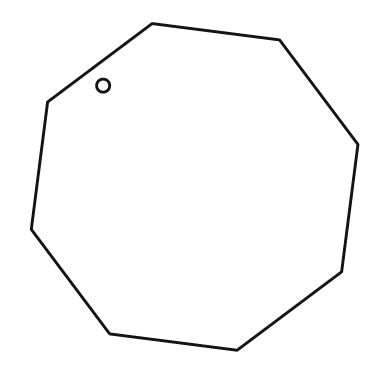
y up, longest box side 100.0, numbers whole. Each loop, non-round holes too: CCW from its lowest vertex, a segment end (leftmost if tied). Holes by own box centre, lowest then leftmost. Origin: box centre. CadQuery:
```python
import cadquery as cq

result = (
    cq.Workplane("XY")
    .moveTo(13.0, -50.0)
    .lineTo(45.0, -26.0)
    .lineTo(50.0, 13.0)
    .lineTo(26.0, 45.0)
    .lineTo(-13.0, 50.0)
    .lineTo(-45.0, 26.0)
    .lineTo(-50.0, -13.0)
    .lineTo(-26.0, -45.0)
    .close()
    .moveTo(-28.0, 31.0)
    .circle(2.0)
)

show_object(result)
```